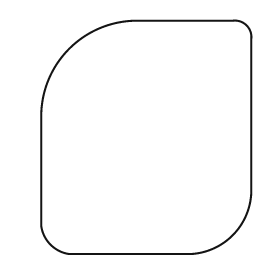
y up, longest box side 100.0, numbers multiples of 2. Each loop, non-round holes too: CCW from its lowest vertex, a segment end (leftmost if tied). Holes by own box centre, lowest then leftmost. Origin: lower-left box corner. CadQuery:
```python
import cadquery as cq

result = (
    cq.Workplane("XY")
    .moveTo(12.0, 0.0)
    .lineTo(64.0, 0.0)
    .threePointArc((82.0, 8.0), (90.0, 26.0))
    .lineTo(90.0, 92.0)
    .threePointArc((88.0, 98.0), (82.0, 100.0))
    .lineTo(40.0, 100.0)
    .threePointArc((12.0, 88.0), (0.0, 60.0))
    .lineTo(0.0, 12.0)
    .threePointArc((4.0, 4.0), (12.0, 0.0))
    .close()
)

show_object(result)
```